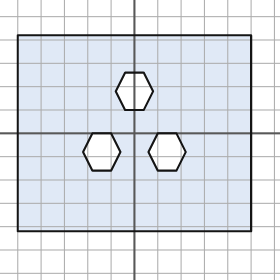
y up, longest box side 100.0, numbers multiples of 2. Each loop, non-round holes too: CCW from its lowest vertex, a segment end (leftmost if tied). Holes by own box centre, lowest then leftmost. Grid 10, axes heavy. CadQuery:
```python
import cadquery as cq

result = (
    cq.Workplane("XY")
    .moveTo(-50.0, -42.0)
    .lineTo(50.0, -42.0)
    .lineTo(50.0, 42.0)
    .lineTo(-50.0, 42.0)
    .close()
    .moveTo(-18.0, -16.0)
    .lineTo(-10.0, -16.0)
    .lineTo(-6.0, -8.0)
    .lineTo(-10.0, 0.0)
    .lineTo(-18.0, 0.0)
    .lineTo(-22.0, -8.0)
    .close()
    .moveTo(10.0, -16.0)
    .lineTo(18.0, -16.0)
    .lineTo(22.0, -8.0)
    .lineTo(18.0, 0.0)
    .lineTo(10.0, 0.0)
    .lineTo(6.0, -8.0)
    .close()
    .moveTo(-4.0, 10.0)
    .lineTo(4.0, 10.0)
    .lineTo(8.0, 18.0)
    .lineTo(4.0, 26.0)
    .lineTo(-4.0, 26.0)
    .lineTo(-8.0, 18.0)
    .close()
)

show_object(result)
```